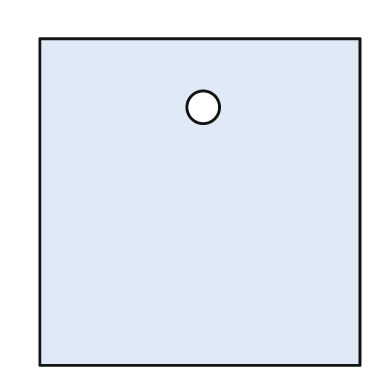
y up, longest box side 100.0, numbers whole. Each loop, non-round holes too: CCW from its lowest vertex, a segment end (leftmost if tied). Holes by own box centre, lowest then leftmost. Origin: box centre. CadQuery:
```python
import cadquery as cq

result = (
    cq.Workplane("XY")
    .moveTo(-49.0, -50.0)
    .lineTo(49.0, -50.0)
    .lineTo(49.0, 50.0)
    .lineTo(-49.0, 50.0)
    .close()
    .moveTo(1.0, 29.0)
    .circle(5.0)
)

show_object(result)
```